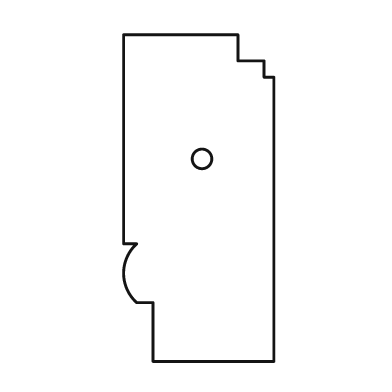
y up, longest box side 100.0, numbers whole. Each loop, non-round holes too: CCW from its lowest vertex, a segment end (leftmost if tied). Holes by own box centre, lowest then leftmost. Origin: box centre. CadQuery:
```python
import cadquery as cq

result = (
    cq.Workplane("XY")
    .moveTo(-14.0, -50.0)
    .lineTo(23.0, -50.0)
    .lineTo(23.0, 37.0)
    .lineTo(20.0, 37.0)
    .lineTo(20.0, 42.0)
    .lineTo(12.0, 42.0)
    .lineTo(12.0, 50.0)
    .lineTo(-23.0, 50.0)
    .lineTo(-23.0, -14.0)
    .lineTo(-19.0, -14.0)
    .threePointArc((-23.0, -23.0), (-19.0, -32.0))
    .lineTo(-14.0, -32.0)
    .close()
    .moveTo(1.0, 12.0)
    .circle(3.0)
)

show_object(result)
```